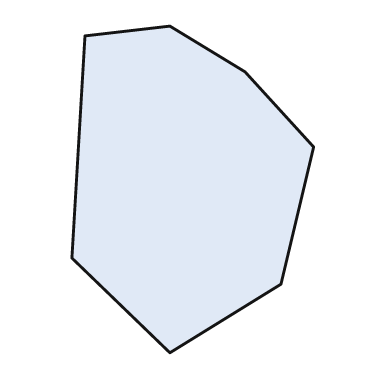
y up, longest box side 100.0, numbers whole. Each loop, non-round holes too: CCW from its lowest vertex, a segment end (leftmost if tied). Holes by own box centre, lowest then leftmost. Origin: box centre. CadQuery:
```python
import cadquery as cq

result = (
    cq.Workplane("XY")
    .moveTo(-7.0, -50.0)
    .lineTo(27.0, -29.0)
    .lineTo(37.0, 13.0)
    .lineTo(16.0, 36.0)
    .lineTo(-7.0, 50.0)
    .lineTo(-33.0, 47.0)
    .lineTo(-37.0, -21.0)
    .close()
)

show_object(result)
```